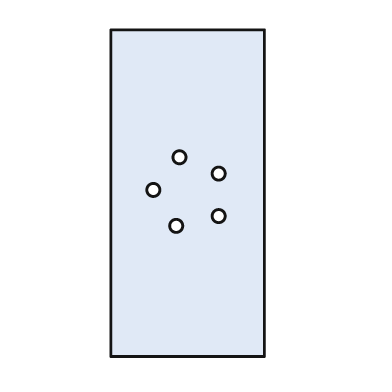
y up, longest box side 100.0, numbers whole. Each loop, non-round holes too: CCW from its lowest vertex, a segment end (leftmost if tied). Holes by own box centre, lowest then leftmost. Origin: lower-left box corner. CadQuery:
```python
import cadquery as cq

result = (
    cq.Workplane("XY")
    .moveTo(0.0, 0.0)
    .lineTo(47.0, 0.0)
    .lineTo(47.0, 100.0)
    .lineTo(0.0, 100.0)
    .close()
    .moveTo(20.0, 40.0)
    .circle(2.0)
    .moveTo(33.0, 43.0)
    .circle(2.0)
    .moveTo(13.0, 51.0)
    .circle(2.0)
    .moveTo(33.0, 56.0)
    .circle(2.0)
    .moveTo(21.0, 61.0)
    .circle(2.0)
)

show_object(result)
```